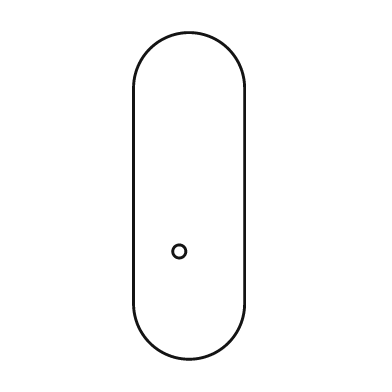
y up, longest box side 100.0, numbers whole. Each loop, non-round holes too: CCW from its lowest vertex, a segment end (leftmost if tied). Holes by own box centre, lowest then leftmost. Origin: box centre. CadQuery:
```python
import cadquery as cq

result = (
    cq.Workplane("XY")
    .moveTo(-17.0, -33.0)
    .threePointArc((0.0, -50.0), (17.0, -33.0))
    .lineTo(17.0, 33.0)
    .threePointArc((0.0, 50.0), (-17.0, 33.0))
    .close()
    .moveTo(-3.0, -17.0)
    .circle(2.0)
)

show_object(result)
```